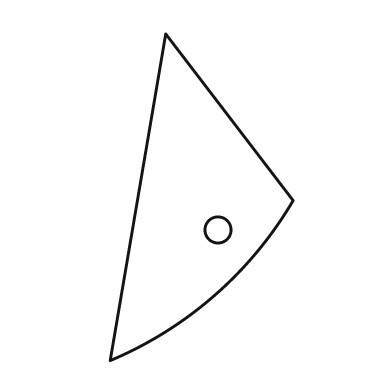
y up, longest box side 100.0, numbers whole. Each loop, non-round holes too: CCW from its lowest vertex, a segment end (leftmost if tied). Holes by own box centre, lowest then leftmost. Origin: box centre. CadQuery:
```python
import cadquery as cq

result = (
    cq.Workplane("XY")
    .moveTo(-28.0, -50.0)
    .threePointArc((4.0, -30.0), (28.0, -1.0))
    .lineTo(-11.0, 50.0)
    .close()
    .moveTo(5.0, -10.0)
    .circle(4.0)
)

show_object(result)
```